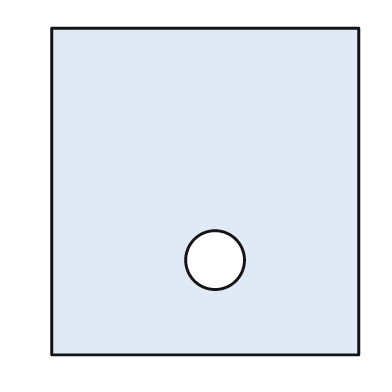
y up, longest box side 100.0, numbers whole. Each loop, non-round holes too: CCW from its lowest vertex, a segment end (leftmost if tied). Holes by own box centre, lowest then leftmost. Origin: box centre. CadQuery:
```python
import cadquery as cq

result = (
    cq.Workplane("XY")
    .moveTo(-47.0, -50.0)
    .lineTo(47.0, -50.0)
    .lineTo(47.0, 50.0)
    .lineTo(-47.0, 50.0)
    .close()
    .moveTo(3.0, -21.0)
    .circle(9.0)
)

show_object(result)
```